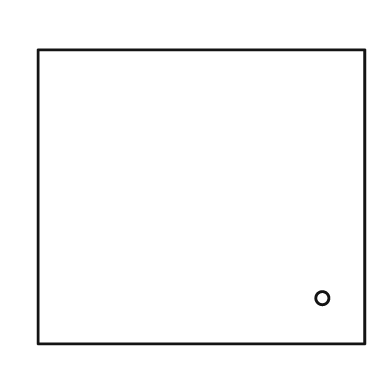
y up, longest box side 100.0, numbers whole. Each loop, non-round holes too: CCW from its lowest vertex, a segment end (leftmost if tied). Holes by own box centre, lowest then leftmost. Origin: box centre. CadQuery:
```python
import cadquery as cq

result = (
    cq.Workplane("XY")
    .moveTo(-50.0, -45.0)
    .lineTo(50.0, -45.0)
    .lineTo(50.0, 45.0)
    .lineTo(-50.0, 45.0)
    .close()
    .moveTo(37.0, -31.0)
    .circle(2.0)
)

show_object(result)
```